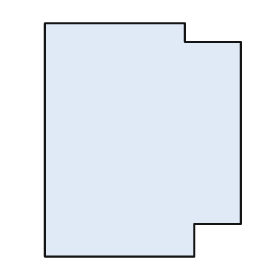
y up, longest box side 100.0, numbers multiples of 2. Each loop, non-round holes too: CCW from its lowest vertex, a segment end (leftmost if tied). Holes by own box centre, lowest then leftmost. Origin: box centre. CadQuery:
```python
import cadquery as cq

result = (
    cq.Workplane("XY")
    .moveTo(-42.0, -50.0)
    .lineTo(22.0, -50.0)
    .lineTo(22.0, -36.0)
    .lineTo(42.0, -36.0)
    .lineTo(42.0, 42.0)
    .lineTo(18.0, 42.0)
    .lineTo(18.0, 50.0)
    .lineTo(-42.0, 50.0)
    .close()
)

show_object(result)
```